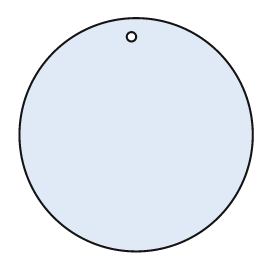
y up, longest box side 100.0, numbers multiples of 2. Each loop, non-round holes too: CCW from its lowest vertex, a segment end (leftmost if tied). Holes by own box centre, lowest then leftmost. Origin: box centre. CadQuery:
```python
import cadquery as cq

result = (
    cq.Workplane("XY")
    .moveTo(0.0, 0.0)
    .circle(50.0)
    .moveTo(-2.0, 42.0)
    .circle(2.0)
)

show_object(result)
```